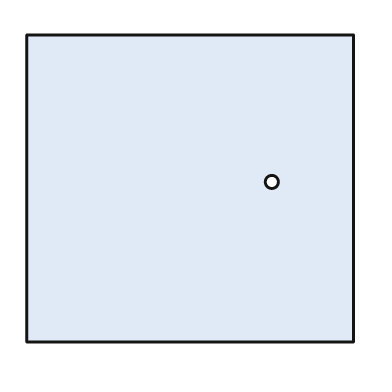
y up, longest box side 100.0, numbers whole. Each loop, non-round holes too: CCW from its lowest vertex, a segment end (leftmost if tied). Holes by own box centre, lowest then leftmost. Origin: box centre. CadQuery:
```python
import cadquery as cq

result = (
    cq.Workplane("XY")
    .moveTo(-50.0, -47.0)
    .lineTo(50.0, -47.0)
    .lineTo(50.0, 47.0)
    .lineTo(-50.0, 47.0)
    .close()
    .moveTo(25.0, 2.0)
    .circle(2.0)
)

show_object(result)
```